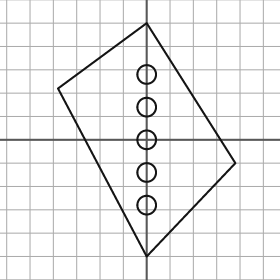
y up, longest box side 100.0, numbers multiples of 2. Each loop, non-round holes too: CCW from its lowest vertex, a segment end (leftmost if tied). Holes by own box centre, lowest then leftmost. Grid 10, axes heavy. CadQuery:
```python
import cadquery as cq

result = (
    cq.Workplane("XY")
    .moveTo(0.0, -50.0)
    .lineTo(38.0, -10.0)
    .lineTo(0.0, 50.0)
    .lineTo(-38.0, 22.0)
    .close()
    .moveTo(0.0, -28.0)
    .circle(4.0)
    .moveTo(0.0, -14.0)
    .circle(4.0)
    .moveTo(0.0, 0.0)
    .circle(4.0)
    .moveTo(0.0, 14.0)
    .circle(4.0)
    .moveTo(0.0, 28.0)
    .circle(4.0)
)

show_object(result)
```